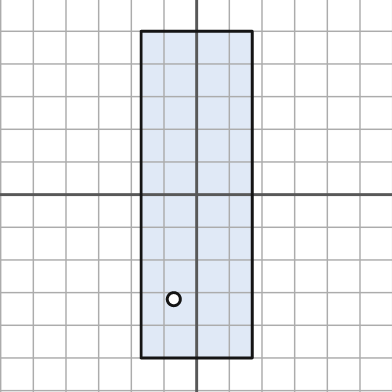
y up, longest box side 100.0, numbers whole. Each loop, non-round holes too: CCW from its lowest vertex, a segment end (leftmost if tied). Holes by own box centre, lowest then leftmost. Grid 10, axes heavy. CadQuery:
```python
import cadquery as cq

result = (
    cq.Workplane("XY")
    .moveTo(-17.0, -50.0)
    .lineTo(17.0, -50.0)
    .lineTo(17.0, 50.0)
    .lineTo(-17.0, 50.0)
    .close()
    .moveTo(-7.0, -32.0)
    .circle(2.0)
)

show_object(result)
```